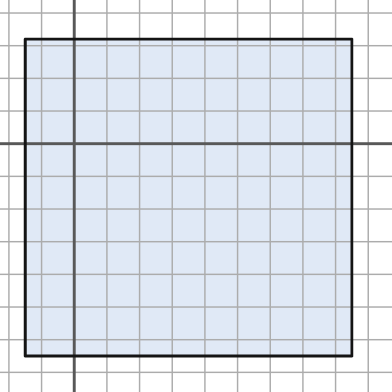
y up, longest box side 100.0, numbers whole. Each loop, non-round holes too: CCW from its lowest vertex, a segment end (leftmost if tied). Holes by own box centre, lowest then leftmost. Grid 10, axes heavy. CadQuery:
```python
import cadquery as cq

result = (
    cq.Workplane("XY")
    .moveTo(-15.0, -65.0)
    .lineTo(85.0, -65.0)
    .lineTo(85.0, 32.0)
    .lineTo(-15.0, 32.0)
    .close()
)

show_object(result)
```